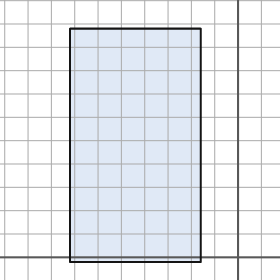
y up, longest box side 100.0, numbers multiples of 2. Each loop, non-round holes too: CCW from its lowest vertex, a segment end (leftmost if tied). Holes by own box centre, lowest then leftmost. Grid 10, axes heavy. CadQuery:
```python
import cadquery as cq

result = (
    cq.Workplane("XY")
    .moveTo(-72.0, -2.0)
    .lineTo(-16.0, -2.0)
    .lineTo(-16.0, 98.0)
    .lineTo(-72.0, 98.0)
    .close()
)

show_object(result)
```